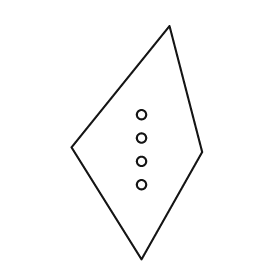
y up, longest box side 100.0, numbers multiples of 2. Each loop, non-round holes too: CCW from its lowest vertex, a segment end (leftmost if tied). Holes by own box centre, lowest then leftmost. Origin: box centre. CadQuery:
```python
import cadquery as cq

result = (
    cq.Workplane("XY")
    .moveTo(2.0, -50.0)
    .lineTo(28.0, -4.0)
    .lineTo(14.0, 50.0)
    .lineTo(-28.0, -2.0)
    .close()
    .moveTo(2.0, -18.0)
    .circle(2.0)
    .moveTo(2.0, -8.0)
    .circle(2.0)
    .moveTo(2.0, 2.0)
    .circle(2.0)
    .moveTo(2.0, 12.0)
    .circle(2.0)
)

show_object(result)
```